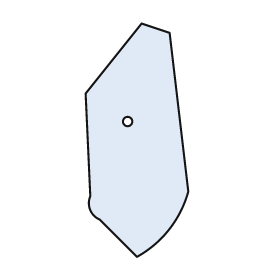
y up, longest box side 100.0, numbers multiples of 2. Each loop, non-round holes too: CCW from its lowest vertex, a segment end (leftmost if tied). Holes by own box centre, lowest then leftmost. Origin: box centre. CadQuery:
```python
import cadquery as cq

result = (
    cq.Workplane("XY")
    .moveTo(0.0, -50.0)
    .threePointArc((14.0, -38.0), (22.0, -22.0))
    .lineTo(14.0, 46.0)
    .lineTo(2.0, 50.0)
    .lineTo(-22.0, 20.0)
    .lineTo(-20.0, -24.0)
    .threePointArc((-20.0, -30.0), (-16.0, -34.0))
    .close()
    .moveTo(-4.0, 8.0)
    .circle(2.0)
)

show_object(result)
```